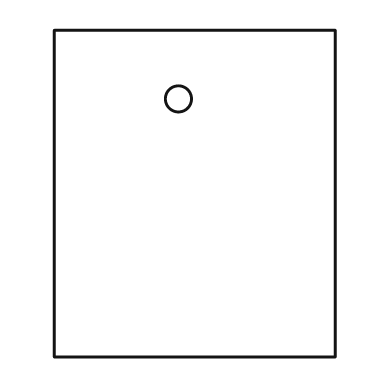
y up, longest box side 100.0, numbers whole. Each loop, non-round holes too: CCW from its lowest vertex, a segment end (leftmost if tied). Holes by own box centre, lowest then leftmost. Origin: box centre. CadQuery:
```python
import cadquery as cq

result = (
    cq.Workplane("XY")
    .moveTo(-43.0, -50.0)
    .lineTo(43.0, -50.0)
    .lineTo(43.0, 50.0)
    .lineTo(-43.0, 50.0)
    .close()
    .moveTo(-5.0, 29.0)
    .circle(4.0)
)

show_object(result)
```